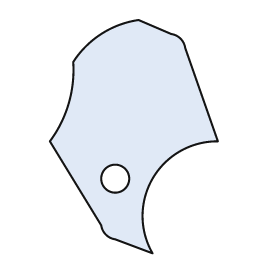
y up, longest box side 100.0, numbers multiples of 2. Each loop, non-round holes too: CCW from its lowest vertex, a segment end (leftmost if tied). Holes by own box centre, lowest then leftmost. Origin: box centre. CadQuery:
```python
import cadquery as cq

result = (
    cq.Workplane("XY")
    .moveTo(8.0, -50.0)
    .threePointArc((8.0, -18.0), (36.0, -2.0))
    .lineTo(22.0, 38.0)
    .threePointArc((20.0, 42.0), (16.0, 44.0))
    .lineTo(2.0, 50.0)
    .threePointArc((-14.0, 44.0), (-26.0, 32.0))
    .threePointArc((-28.0, 14.0), (-36.0, -2.0))
    .lineTo(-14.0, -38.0)
    .threePointArc((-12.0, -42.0), (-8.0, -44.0))
    .close()
    .moveTo(-8.0, -18.0)
    .circle(6.0)
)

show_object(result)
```